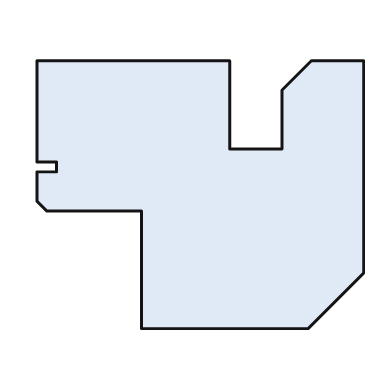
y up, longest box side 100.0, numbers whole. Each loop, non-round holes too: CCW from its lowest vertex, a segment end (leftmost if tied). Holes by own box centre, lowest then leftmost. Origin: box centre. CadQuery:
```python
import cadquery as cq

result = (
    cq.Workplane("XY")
    .moveTo(-18.0, -41.0)
    .lineTo(33.0, -41.0)
    .lineTo(50.0, -24.0)
    .lineTo(50.0, 41.0)
    .lineTo(34.0, 41.0)
    .lineTo(25.0, 32.0)
    .lineTo(25.0, 14.0)
    .lineTo(9.0, 14.0)
    .lineTo(9.0, 41.0)
    .lineTo(-50.0, 41.0)
    .lineTo(-50.0, 10.0)
    .lineTo(-44.0, 10.0)
    .lineTo(-44.0, 7.0)
    .lineTo(-50.0, 7.0)
    .lineTo(-50.0, -2.0)
    .lineTo(-47.0, -5.0)
    .lineTo(-18.0, -5.0)
    .close()
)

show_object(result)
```